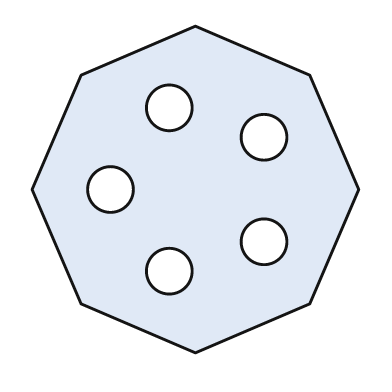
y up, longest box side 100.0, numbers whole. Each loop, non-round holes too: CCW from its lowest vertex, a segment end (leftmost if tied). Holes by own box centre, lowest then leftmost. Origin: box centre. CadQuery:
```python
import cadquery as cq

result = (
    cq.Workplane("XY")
    .moveTo(0.0, -50.0)
    .lineTo(35.0, -35.0)
    .lineTo(50.0, 0.0)
    .lineTo(35.0, 35.0)
    .lineTo(0.0, 50.0)
    .lineTo(-35.0, 35.0)
    .lineTo(-50.0, 0.0)
    .lineTo(-35.0, -35.0)
    .close()
    .moveTo(-8.0, -25.0)
    .circle(7.0)
    .moveTo(21.0, -16.0)
    .circle(7.0)
    .moveTo(-26.0, 0.0)
    .circle(7.0)
    .moveTo(21.0, 16.0)
    .circle(7.0)
    .moveTo(-8.0, 25.0)
    .circle(7.0)
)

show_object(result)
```